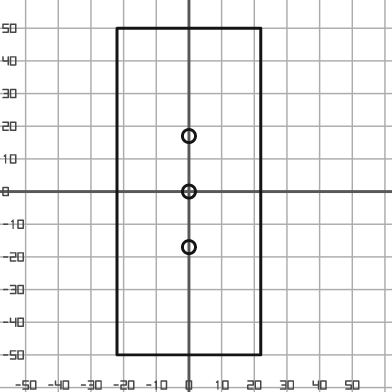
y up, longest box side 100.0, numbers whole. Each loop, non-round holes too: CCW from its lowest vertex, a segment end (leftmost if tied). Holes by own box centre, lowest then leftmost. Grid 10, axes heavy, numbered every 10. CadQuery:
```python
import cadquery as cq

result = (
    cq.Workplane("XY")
    .moveTo(-22.0, -50.0)
    .lineTo(22.0, -50.0)
    .lineTo(22.0, 50.0)
    .lineTo(-22.0, 50.0)
    .close()
    .moveTo(0.0, -17.0)
    .circle(2.0)
    .moveTo(0.0, 0.0)
    .circle(2.0)
    .moveTo(0.0, 17.0)
    .circle(2.0)
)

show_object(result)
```